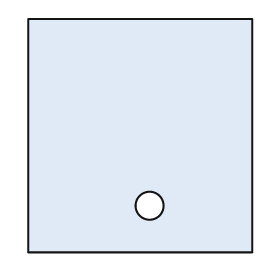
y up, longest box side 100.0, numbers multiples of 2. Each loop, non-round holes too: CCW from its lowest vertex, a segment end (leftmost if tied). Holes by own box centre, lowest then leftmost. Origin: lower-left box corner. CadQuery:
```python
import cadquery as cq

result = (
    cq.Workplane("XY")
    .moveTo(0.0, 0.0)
    .lineTo(96.0, 0.0)
    .lineTo(96.0, 100.0)
    .lineTo(0.0, 100.0)
    .close()
    .moveTo(52.0, 20.0)
    .circle(6.0)
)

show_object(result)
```